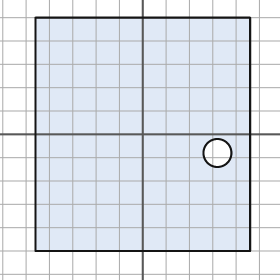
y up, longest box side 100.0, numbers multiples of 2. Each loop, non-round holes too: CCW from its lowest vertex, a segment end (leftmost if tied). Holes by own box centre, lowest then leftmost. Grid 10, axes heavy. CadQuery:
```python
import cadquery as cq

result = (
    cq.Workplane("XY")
    .moveTo(-46.0, -50.0)
    .lineTo(46.0, -50.0)
    .lineTo(46.0, 50.0)
    .lineTo(-46.0, 50.0)
    .close()
    .moveTo(32.0, -8.0)
    .circle(6.0)
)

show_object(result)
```